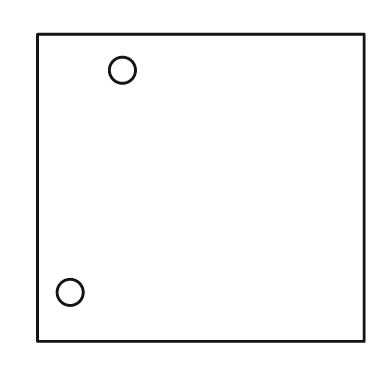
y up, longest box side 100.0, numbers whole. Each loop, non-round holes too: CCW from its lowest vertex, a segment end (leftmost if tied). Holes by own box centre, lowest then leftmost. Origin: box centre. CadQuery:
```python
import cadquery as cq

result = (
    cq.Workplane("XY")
    .moveTo(-50.0, -47.0)
    .lineTo(50.0, -47.0)
    .lineTo(50.0, 47.0)
    .lineTo(-50.0, 47.0)
    .close()
    .moveTo(-40.0, -32.0)
    .circle(4.0)
    .moveTo(-24.0, 36.0)
    .circle(4.0)
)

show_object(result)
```